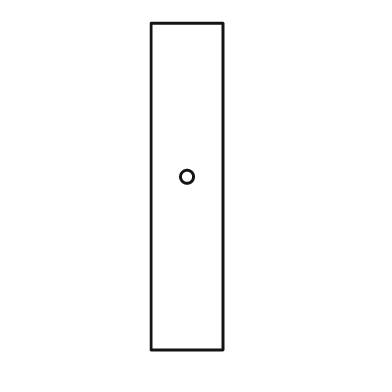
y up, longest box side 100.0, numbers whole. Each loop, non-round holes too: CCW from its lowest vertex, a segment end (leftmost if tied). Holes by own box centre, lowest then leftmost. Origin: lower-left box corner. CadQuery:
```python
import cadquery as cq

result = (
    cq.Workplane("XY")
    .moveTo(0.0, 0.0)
    .lineTo(22.0, 0.0)
    .lineTo(22.0, 100.0)
    .lineTo(0.0, 100.0)
    .close()
    .moveTo(11.0, 53.0)
    .circle(2.0)
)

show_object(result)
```